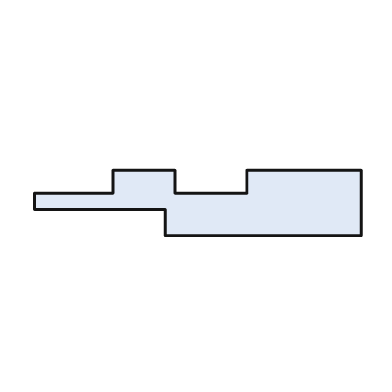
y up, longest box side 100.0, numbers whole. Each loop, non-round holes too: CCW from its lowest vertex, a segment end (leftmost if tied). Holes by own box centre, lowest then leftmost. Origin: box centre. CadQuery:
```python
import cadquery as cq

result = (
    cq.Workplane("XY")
    .moveTo(-10.0, -10.0)
    .lineTo(50.0, -10.0)
    .lineTo(50.0, 10.0)
    .lineTo(15.0, 10.0)
    .lineTo(15.0, 3.0)
    .lineTo(-7.0, 3.0)
    .lineTo(-7.0, 10.0)
    .lineTo(-26.0, 10.0)
    .lineTo(-26.0, 3.0)
    .lineTo(-50.0, 3.0)
    .lineTo(-50.0, -2.0)
    .lineTo(-10.0, -2.0)
    .close()
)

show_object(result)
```